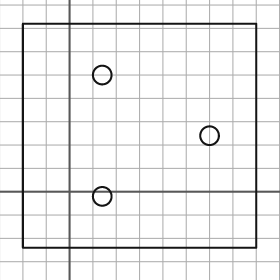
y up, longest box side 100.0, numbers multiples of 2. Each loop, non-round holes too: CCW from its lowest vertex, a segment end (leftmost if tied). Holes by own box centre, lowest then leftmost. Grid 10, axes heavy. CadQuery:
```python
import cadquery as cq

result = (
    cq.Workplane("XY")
    .moveTo(-20.0, -24.0)
    .lineTo(80.0, -24.0)
    .lineTo(80.0, 72.0)
    .lineTo(-20.0, 72.0)
    .close()
    .moveTo(14.0, -2.0)
    .circle(4.0)
    .moveTo(60.0, 24.0)
    .circle(4.0)
    .moveTo(14.0, 50.0)
    .circle(4.0)
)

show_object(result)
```